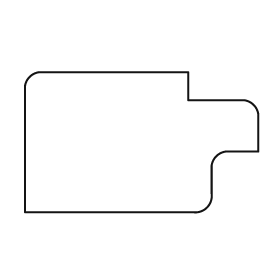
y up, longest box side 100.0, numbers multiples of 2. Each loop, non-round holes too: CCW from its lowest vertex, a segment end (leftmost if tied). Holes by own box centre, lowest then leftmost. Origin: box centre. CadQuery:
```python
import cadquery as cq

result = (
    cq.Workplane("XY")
    .moveTo(-50.0, -30.0)
    .lineTo(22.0, -30.0)
    .threePointArc((28.0, -28.0), (30.0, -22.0))
    .lineTo(30.0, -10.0)
    .threePointArc((32.0, -6.0), (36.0, -4.0))
    .lineTo(50.0, -4.0)
    .lineTo(50.0, 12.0)
    .threePointArc((48.0, 16.0), (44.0, 18.0))
    .lineTo(20.0, 18.0)
    .lineTo(20.0, 30.0)
    .lineTo(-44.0, 30.0)
    .threePointArc((-48.0, 28.0), (-50.0, 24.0))
    .close()
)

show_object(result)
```